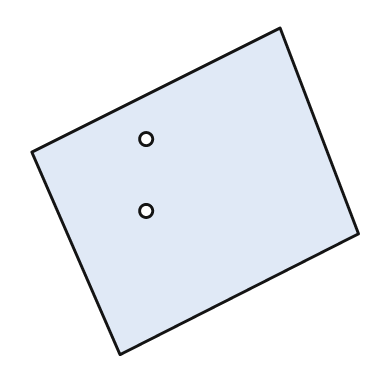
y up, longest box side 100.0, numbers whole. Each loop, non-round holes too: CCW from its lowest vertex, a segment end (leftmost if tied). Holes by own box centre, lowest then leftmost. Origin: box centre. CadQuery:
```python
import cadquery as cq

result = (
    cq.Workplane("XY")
    .moveTo(-23.0, -50.0)
    .lineTo(50.0, -13.0)
    .lineTo(26.0, 50.0)
    .lineTo(-50.0, 12.0)
    .close()
    .moveTo(-15.0, -6.0)
    .circle(2.0)
    .moveTo(-15.0, 16.0)
    .circle(2.0)
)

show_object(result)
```